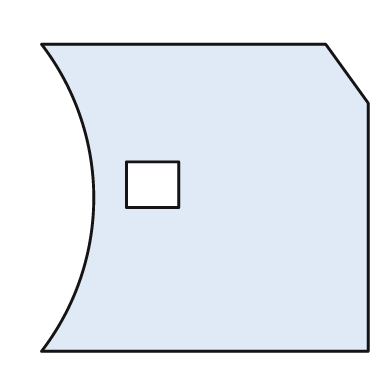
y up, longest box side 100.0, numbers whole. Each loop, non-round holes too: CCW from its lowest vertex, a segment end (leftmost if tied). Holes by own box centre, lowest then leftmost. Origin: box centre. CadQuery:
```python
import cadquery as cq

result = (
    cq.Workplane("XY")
    .moveTo(-50.0, -47.0)
    .lineTo(50.0, -47.0)
    .lineTo(50.0, 29.0)
    .lineTo(37.0, 47.0)
    .lineTo(-50.0, 47.0)
    .threePointArc((-34.0, 0.0), (-50.0, -47.0))
    .close()
    .moveTo(-24.0, -3.0)
    .lineTo(-8.0, -3.0)
    .lineTo(-8.0, 11.0)
    .lineTo(-24.0, 11.0)
    .close()
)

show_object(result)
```